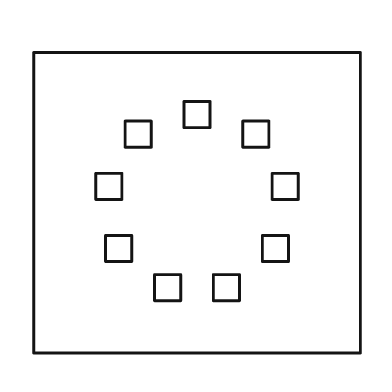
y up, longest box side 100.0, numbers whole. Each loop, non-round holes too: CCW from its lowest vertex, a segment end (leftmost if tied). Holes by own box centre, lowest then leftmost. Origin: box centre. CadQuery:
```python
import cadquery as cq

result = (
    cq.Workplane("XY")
    .moveTo(-50.0, -46.0)
    .lineTo(50.0, -46.0)
    .lineTo(50.0, 46.0)
    .lineTo(-50.0, 46.0)
    .close()
    .moveTo(-13.0, -30.0)
    .lineTo(-5.0, -30.0)
    .lineTo(-5.0, -22.0)
    .lineTo(-13.0, -22.0)
    .close()
    .moveTo(5.0, -30.0)
    .lineTo(13.0, -30.0)
    .lineTo(13.0, -22.0)
    .lineTo(5.0, -22.0)
    .close()
    .moveTo(-28.0, -18.0)
    .lineTo(-20.0, -18.0)
    .lineTo(-20.0, -10.0)
    .lineTo(-28.0, -10.0)
    .close()
    .moveTo(20.0, -18.0)
    .lineTo(28.0, -18.0)
    .lineTo(28.0, -10.0)
    .lineTo(20.0, -10.0)
    .close()
    .moveTo(-31.0, 1.0)
    .lineTo(-23.0, 1.0)
    .lineTo(-23.0, 9.0)
    .lineTo(-31.0, 9.0)
    .close()
    .moveTo(23.0, 1.0)
    .lineTo(31.0, 1.0)
    .lineTo(31.0, 9.0)
    .lineTo(23.0, 9.0)
    .close()
    .moveTo(-22.0, 17.0)
    .lineTo(-14.0, 17.0)
    .lineTo(-14.0, 25.0)
    .lineTo(-22.0, 25.0)
    .close()
    .moveTo(14.0, 17.0)
    .lineTo(22.0, 17.0)
    .lineTo(22.0, 25.0)
    .lineTo(14.0, 25.0)
    .close()
    .moveTo(-4.0, 23.0)
    .lineTo(4.0, 23.0)
    .lineTo(4.0, 31.0)
    .lineTo(-4.0, 31.0)
    .close()
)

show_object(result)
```